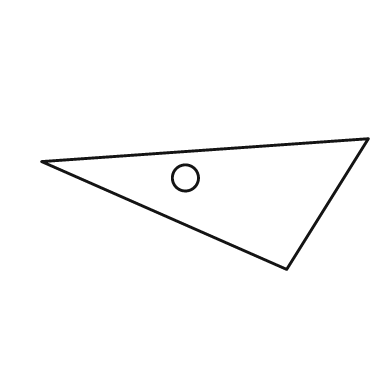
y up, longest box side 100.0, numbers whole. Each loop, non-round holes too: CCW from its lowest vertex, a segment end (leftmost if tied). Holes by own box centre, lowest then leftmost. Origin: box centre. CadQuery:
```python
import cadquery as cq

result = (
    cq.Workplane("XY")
    .moveTo(25.0, -20.0)
    .lineTo(50.0, 20.0)
    .lineTo(-50.0, 13.0)
    .close()
    .moveTo(-6.0, 8.0)
    .circle(4.0)
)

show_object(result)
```